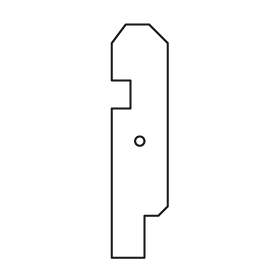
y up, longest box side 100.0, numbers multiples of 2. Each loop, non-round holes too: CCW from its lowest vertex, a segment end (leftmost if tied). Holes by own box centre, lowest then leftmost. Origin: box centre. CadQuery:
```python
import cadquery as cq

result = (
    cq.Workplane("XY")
    .moveTo(-12.0, -50.0)
    .lineTo(2.0, -50.0)
    .lineTo(2.0, -32.0)
    .lineTo(8.0, -32.0)
    .lineTo(12.0, -28.0)
    .lineTo(12.0, 42.0)
    .lineTo(4.0, 50.0)
    .lineTo(-6.0, 50.0)
    .lineTo(-12.0, 42.0)
    .lineTo(-12.0, 26.0)
    .lineTo(-4.0, 26.0)
    .lineTo(-4.0, 14.0)
    .lineTo(-12.0, 14.0)
    .close()
    .moveTo(0.0, 0.0)
    .circle(2.0)
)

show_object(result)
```